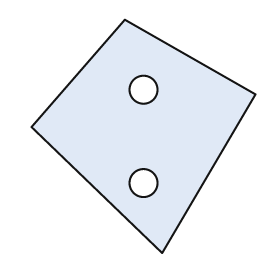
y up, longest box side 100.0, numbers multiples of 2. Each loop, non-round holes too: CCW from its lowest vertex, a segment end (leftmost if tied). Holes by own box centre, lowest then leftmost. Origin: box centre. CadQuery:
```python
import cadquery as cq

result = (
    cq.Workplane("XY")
    .moveTo(8.0, -50.0)
    .lineTo(48.0, 18.0)
    .lineTo(-8.0, 50.0)
    .lineTo(-48.0, 4.0)
    .close()
    .moveTo(0.0, -20.0)
    .circle(6.0)
    .moveTo(0.0, 20.0)
    .circle(6.0)
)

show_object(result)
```